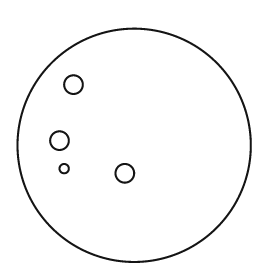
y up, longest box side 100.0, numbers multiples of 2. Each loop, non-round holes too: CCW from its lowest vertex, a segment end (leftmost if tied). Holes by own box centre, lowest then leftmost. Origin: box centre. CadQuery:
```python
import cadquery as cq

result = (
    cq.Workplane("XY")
    .moveTo(0.0, 0.0)
    .circle(50.0)
    .moveTo(-4.0, -12.0)
    .circle(4.0)
    .moveTo(-30.0, -10.0)
    .circle(2.0)
    .moveTo(-32.0, 2.0)
    .circle(4.0)
    .moveTo(-26.0, 26.0)
    .circle(4.0)
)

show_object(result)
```